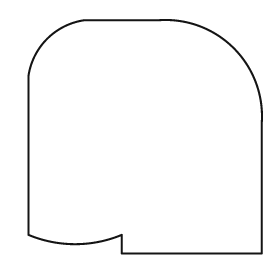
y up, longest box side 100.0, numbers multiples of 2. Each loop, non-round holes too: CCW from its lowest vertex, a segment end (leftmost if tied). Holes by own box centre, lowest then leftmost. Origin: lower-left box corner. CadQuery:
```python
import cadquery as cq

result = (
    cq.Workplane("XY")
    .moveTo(40.0, 0.0)
    .lineTo(100.0, 0.0)
    .lineTo(100.0, 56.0)
    .threePointArc((88.0, 88.0), (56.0, 100.0))
    .lineTo(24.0, 100.0)
    .threePointArc((8.0, 92.0), (0.0, 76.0))
    .lineTo(0.0, 8.0)
    .threePointArc((20.0, 4.0), (40.0, 8.0))
    .close()
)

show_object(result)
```